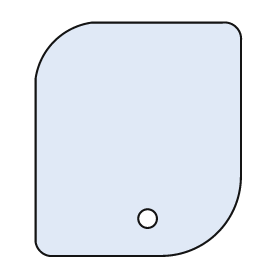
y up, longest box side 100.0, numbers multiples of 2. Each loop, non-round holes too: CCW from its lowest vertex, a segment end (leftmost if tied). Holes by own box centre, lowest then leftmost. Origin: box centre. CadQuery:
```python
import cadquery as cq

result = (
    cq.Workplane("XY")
    .moveTo(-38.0, -50.0)
    .lineTo(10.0, -50.0)
    .threePointArc((34.0, -40.0), (44.0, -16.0))
    .lineTo(44.0, 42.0)
    .threePointArc((42.0, 48.0), (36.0, 50.0))
    .lineTo(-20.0, 50.0)
    .threePointArc((-36.0, 42.0), (-44.0, 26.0))
    .lineTo(-44.0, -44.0)
    .threePointArc((-42.0, -48.0), (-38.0, -50.0))
    .close()
    .moveTo(4.0, -34.0)
    .circle(4.0)
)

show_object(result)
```